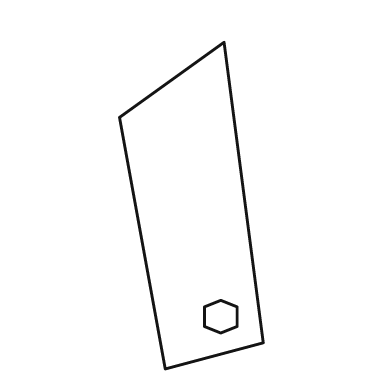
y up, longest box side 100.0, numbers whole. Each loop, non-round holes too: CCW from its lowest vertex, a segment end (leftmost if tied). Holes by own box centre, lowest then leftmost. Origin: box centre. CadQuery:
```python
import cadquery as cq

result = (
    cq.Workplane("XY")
    .moveTo(-8.0, -50.0)
    .lineTo(22.0, -42.0)
    .lineTo(10.0, 50.0)
    .lineTo(-22.0, 27.0)
    .close()
    .moveTo(9.0, -39.0)
    .lineTo(14.0, -37.0)
    .lineTo(14.0, -31.0)
    .lineTo(9.0, -29.0)
    .lineTo(4.0, -31.0)
    .lineTo(4.0, -37.0)
    .close()
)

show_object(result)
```